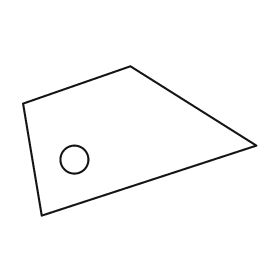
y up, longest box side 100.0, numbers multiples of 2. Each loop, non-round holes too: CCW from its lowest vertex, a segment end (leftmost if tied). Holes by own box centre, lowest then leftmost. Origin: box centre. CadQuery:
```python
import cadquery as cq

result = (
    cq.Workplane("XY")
    .moveTo(-42.0, -32.0)
    .lineTo(50.0, -2.0)
    .lineTo(-4.0, 32.0)
    .lineTo(-50.0, 16.0)
    .close()
    .moveTo(-28.0, -8.0)
    .circle(6.0)
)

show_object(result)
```